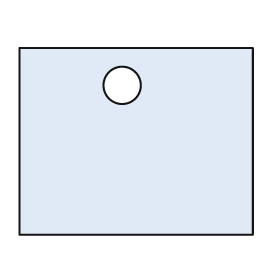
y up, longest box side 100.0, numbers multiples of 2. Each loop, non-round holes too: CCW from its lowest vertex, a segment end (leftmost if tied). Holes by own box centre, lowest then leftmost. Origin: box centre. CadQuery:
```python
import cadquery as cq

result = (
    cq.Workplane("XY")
    .moveTo(-50.0, -40.0)
    .lineTo(50.0, -40.0)
    .lineTo(50.0, 40.0)
    .lineTo(-50.0, 40.0)
    .close()
    .moveTo(-6.0, 24.0)
    .circle(8.0)
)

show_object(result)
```